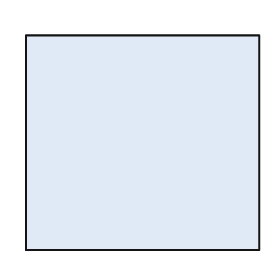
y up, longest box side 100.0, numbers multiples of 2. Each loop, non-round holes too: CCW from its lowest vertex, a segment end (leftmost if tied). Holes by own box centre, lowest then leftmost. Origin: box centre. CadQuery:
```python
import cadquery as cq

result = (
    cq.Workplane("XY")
    .moveTo(-50.0, -46.0)
    .lineTo(50.0, -46.0)
    .lineTo(50.0, 46.0)
    .lineTo(-50.0, 46.0)
    .close()
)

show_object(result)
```